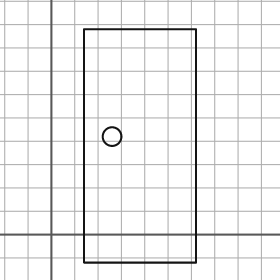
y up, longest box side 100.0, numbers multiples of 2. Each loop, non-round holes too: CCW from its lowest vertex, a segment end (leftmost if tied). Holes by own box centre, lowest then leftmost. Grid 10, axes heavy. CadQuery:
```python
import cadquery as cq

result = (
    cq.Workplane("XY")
    .moveTo(14.0, -12.0)
    .lineTo(62.0, -12.0)
    .lineTo(62.0, 88.0)
    .lineTo(14.0, 88.0)
    .close()
    .moveTo(26.0, 42.0)
    .circle(4.0)
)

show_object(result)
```